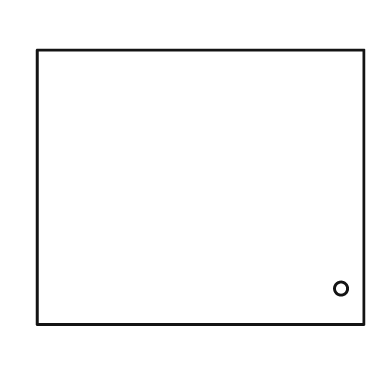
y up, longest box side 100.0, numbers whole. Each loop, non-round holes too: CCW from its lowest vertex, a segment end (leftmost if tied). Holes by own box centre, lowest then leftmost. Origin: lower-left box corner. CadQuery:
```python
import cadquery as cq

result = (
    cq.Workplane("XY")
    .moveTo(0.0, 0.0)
    .lineTo(100.0, 0.0)
    .lineTo(100.0, 84.0)
    .lineTo(0.0, 84.0)
    .close()
    .moveTo(93.0, 11.0)
    .circle(2.0)
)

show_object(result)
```